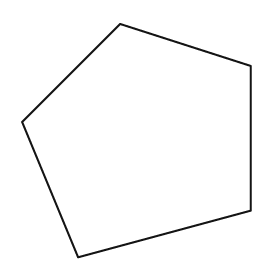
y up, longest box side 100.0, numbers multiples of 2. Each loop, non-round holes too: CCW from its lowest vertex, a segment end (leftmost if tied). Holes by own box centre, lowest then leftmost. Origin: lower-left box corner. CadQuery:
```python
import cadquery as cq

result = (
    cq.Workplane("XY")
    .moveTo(24.0, 0.0)
    .lineTo(98.0, 20.0)
    .lineTo(98.0, 82.0)
    .lineTo(42.0, 100.0)
    .lineTo(0.0, 58.0)
    .close()
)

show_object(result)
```